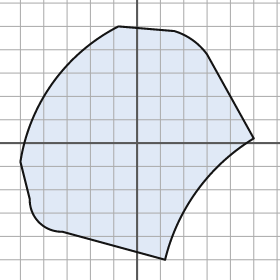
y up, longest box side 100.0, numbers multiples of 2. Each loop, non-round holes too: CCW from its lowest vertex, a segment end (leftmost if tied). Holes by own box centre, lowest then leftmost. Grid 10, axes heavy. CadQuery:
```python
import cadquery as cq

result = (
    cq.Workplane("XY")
    .moveTo(12.0, -50.0)
    .threePointArc((26.0, -20.0), (50.0, 2.0))
    .lineTo(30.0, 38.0)
    .threePointArc((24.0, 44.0), (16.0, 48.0))
    .lineTo(-8.0, 50.0)
    .threePointArc((-36.0, 26.0), (-50.0, -8.0))
    .lineTo(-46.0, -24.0)
    .threePointArc((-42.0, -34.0), (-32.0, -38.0))
    .close()
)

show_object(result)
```